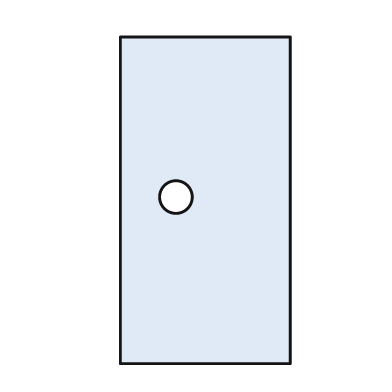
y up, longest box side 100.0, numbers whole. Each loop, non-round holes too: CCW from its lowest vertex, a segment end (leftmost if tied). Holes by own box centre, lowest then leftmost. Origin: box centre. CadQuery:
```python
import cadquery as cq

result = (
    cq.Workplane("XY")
    .moveTo(-26.0, -50.0)
    .lineTo(26.0, -50.0)
    .lineTo(26.0, 50.0)
    .lineTo(-26.0, 50.0)
    .close()
    .moveTo(-9.0, 1.0)
    .circle(5.0)
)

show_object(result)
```